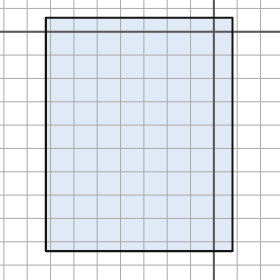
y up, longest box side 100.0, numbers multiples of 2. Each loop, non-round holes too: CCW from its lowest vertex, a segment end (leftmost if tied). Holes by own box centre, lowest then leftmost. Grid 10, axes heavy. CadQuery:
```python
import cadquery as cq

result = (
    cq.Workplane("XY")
    .moveTo(-72.0, -94.0)
    .lineTo(8.0, -94.0)
    .lineTo(8.0, 6.0)
    .lineTo(-72.0, 6.0)
    .close()
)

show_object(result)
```